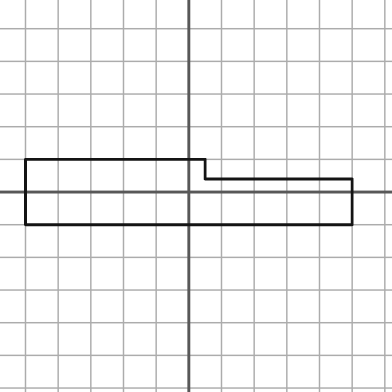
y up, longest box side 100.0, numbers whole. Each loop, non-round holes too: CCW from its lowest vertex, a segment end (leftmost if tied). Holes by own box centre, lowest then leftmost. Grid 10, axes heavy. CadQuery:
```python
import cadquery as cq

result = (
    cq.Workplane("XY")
    .moveTo(-50.0, -10.0)
    .lineTo(50.0, -10.0)
    .lineTo(50.0, 4.0)
    .lineTo(5.0, 4.0)
    .lineTo(5.0, 10.0)
    .lineTo(-50.0, 10.0)
    .close()
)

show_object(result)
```